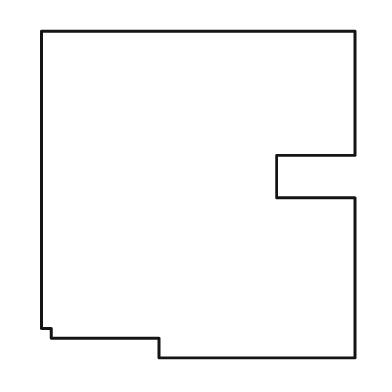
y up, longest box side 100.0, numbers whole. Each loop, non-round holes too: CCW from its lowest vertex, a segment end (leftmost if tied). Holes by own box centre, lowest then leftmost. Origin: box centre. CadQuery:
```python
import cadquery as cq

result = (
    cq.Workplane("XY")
    .moveTo(-12.0, -50.0)
    .lineTo(48.0, -50.0)
    .lineTo(48.0, -1.0)
    .lineTo(24.0, -1.0)
    .lineTo(24.0, 12.0)
    .lineTo(48.0, 12.0)
    .lineTo(48.0, 50.0)
    .lineTo(-48.0, 50.0)
    .lineTo(-48.0, -41.0)
    .lineTo(-45.0, -41.0)
    .lineTo(-45.0, -44.0)
    .lineTo(-12.0, -44.0)
    .close()
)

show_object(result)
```